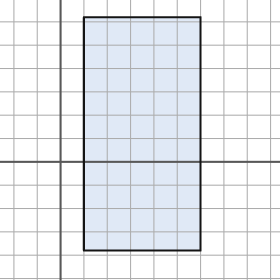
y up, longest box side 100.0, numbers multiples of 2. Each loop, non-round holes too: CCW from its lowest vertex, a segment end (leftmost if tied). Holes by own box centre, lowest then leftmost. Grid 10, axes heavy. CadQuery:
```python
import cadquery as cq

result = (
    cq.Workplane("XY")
    .moveTo(10.0, -38.0)
    .lineTo(60.0, -38.0)
    .lineTo(60.0, 62.0)
    .lineTo(10.0, 62.0)
    .close()
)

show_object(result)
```